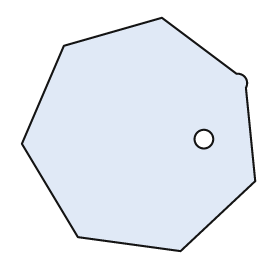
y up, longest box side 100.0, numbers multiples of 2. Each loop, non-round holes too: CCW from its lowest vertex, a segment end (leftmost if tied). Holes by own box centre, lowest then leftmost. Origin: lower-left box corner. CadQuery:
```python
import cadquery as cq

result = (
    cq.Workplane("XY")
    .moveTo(68.0, 0.0)
    .lineTo(100.0, 30.0)
    .lineTo(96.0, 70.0)
    .threePointArc((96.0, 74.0), (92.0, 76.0))
    .lineTo(60.0, 100.0)
    .lineTo(18.0, 88.0)
    .lineTo(0.0, 46.0)
    .lineTo(24.0, 6.0)
    .close()
    .moveTo(78.0, 48.0)
    .circle(4.0)
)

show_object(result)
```